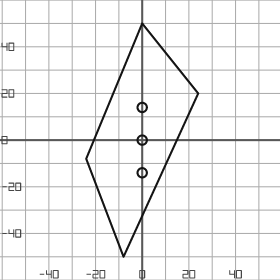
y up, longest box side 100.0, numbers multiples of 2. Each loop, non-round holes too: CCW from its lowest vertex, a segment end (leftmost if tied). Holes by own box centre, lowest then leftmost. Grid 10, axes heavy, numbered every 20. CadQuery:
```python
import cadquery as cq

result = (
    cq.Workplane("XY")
    .moveTo(-8.0, -50.0)
    .lineTo(24.0, 20.0)
    .lineTo(0.0, 50.0)
    .lineTo(-24.0, -8.0)
    .close()
    .moveTo(0.0, -14.0)
    .circle(2.0)
    .moveTo(0.0, 0.0)
    .circle(2.0)
    .moveTo(0.0, 14.0)
    .circle(2.0)
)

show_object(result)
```